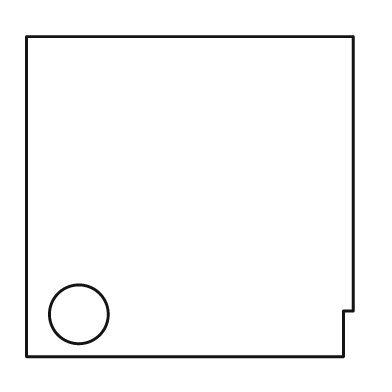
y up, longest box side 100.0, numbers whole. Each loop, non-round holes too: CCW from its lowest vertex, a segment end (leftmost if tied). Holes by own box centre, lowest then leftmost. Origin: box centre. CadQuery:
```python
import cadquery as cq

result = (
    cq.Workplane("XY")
    .moveTo(-50.0, -49.0)
    .lineTo(47.0, -49.0)
    .lineTo(47.0, -35.0)
    .lineTo(50.0, -35.0)
    .lineTo(50.0, 49.0)
    .lineTo(-50.0, 49.0)
    .close()
    .moveTo(-34.0, -36.0)
    .circle(9.0)
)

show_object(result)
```